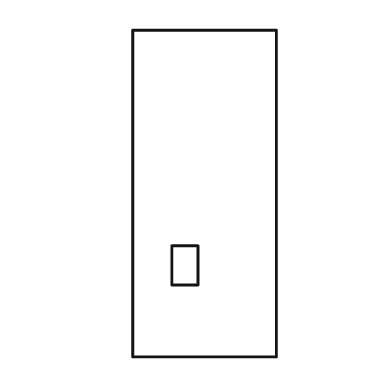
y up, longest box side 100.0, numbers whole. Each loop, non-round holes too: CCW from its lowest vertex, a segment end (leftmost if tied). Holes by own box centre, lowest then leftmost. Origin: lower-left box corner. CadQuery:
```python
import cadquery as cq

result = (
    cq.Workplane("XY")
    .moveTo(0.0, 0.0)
    .lineTo(44.0, 0.0)
    .lineTo(44.0, 100.0)
    .lineTo(0.0, 100.0)
    .close()
    .moveTo(12.0, 22.0)
    .lineTo(20.0, 22.0)
    .lineTo(20.0, 34.0)
    .lineTo(12.0, 34.0)
    .close()
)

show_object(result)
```